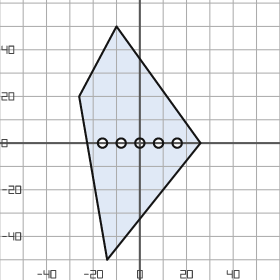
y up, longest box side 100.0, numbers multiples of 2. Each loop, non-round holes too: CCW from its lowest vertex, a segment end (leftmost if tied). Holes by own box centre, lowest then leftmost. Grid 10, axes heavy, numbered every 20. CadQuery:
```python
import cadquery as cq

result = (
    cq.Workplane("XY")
    .moveTo(-14.0, -50.0)
    .lineTo(26.0, 0.0)
    .lineTo(-10.0, 50.0)
    .lineTo(-26.0, 20.0)
    .close()
    .moveTo(-16.0, 0.0)
    .circle(2.0)
    .moveTo(-8.0, 0.0)
    .circle(2.0)
    .moveTo(0.0, 0.0)
    .circle(2.0)
    .moveTo(8.0, 0.0)
    .circle(2.0)
    .moveTo(16.0, 0.0)
    .circle(2.0)
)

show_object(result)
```